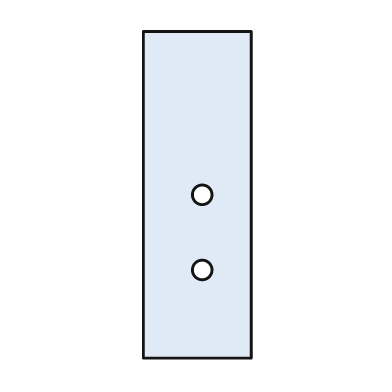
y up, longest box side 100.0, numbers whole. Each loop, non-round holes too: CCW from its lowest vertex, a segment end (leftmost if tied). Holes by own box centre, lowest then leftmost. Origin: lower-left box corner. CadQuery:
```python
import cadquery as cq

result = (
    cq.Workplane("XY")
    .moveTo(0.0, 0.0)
    .lineTo(33.0, 0.0)
    .lineTo(33.0, 100.0)
    .lineTo(0.0, 100.0)
    .close()
    .moveTo(18.0, 27.0)
    .circle(3.0)
    .moveTo(18.0, 50.0)
    .circle(3.0)
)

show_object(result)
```